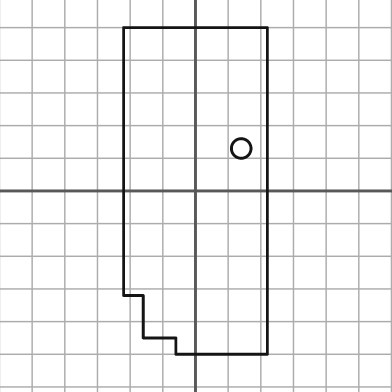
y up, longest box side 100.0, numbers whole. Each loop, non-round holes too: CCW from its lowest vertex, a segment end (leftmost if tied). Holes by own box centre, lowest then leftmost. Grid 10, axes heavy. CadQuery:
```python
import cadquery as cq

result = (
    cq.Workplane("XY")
    .moveTo(-6.0, -50.0)
    .lineTo(22.0, -50.0)
    .lineTo(22.0, 50.0)
    .lineTo(-22.0, 50.0)
    .lineTo(-22.0, -32.0)
    .lineTo(-16.0, -32.0)
    .lineTo(-16.0, -45.0)
    .lineTo(-6.0, -45.0)
    .close()
    .moveTo(14.0, 13.0)
    .circle(3.0)
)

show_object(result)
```